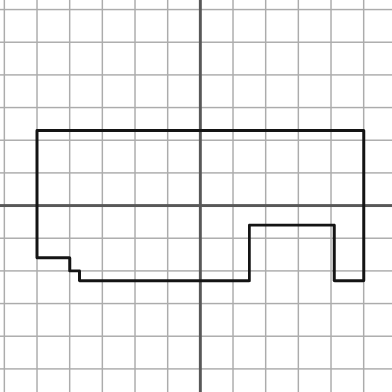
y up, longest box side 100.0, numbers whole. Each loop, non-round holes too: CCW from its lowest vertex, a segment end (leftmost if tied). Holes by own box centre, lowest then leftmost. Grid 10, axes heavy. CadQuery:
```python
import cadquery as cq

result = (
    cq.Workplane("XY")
    .moveTo(-37.0, -23.0)
    .lineTo(15.0, -23.0)
    .lineTo(15.0, -6.0)
    .lineTo(41.0, -6.0)
    .lineTo(41.0, -23.0)
    .lineTo(50.0, -23.0)
    .lineTo(50.0, 23.0)
    .lineTo(-50.0, 23.0)
    .lineTo(-50.0, -16.0)
    .lineTo(-40.0, -16.0)
    .lineTo(-40.0, -20.0)
    .lineTo(-37.0, -20.0)
    .close()
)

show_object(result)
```